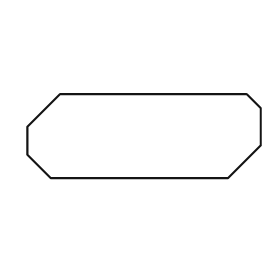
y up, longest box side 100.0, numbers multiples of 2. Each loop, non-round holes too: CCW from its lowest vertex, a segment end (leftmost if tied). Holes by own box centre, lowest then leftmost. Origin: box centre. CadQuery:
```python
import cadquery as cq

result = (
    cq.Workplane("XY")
    .moveTo(-40.0, -18.0)
    .lineTo(36.0, -18.0)
    .lineTo(50.0, -4.0)
    .lineTo(50.0, 12.0)
    .lineTo(44.0, 18.0)
    .lineTo(-36.0, 18.0)
    .lineTo(-50.0, 4.0)
    .lineTo(-50.0, -8.0)
    .close()
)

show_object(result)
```